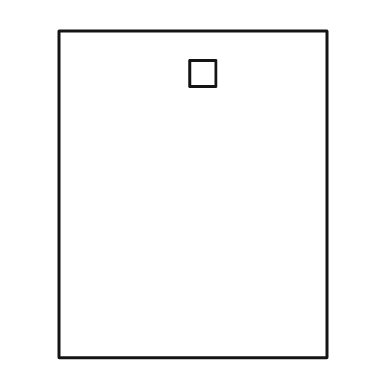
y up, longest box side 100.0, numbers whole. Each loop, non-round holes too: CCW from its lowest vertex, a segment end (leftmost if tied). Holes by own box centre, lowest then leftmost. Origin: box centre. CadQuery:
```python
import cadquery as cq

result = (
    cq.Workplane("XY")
    .moveTo(-41.0, -50.0)
    .lineTo(41.0, -50.0)
    .lineTo(41.0, 50.0)
    .lineTo(-41.0, 50.0)
    .close()
    .moveTo(-1.0, 33.0)
    .lineTo(7.0, 33.0)
    .lineTo(7.0, 41.0)
    .lineTo(-1.0, 41.0)
    .close()
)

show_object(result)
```